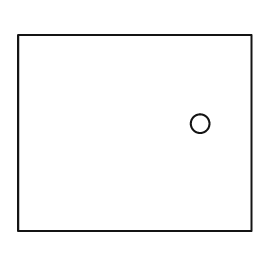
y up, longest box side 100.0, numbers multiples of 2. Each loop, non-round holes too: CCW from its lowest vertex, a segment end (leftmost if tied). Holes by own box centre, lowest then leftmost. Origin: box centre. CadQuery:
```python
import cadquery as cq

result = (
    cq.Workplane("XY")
    .moveTo(-50.0, -42.0)
    .lineTo(50.0, -42.0)
    .lineTo(50.0, 42.0)
    .lineTo(-50.0, 42.0)
    .close()
    .moveTo(28.0, 4.0)
    .circle(4.0)
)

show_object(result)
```